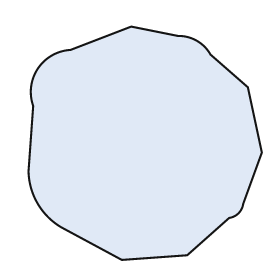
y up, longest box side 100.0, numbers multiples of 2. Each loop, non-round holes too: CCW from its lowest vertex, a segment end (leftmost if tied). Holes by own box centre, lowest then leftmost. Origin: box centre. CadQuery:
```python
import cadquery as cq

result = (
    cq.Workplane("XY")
    .moveTo(-10.0, -50.0)
    .lineTo(18.0, -48.0)
    .lineTo(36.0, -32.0)
    .threePointArc((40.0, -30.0), (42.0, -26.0))
    .lineTo(50.0, -4.0)
    .lineTo(44.0, 24.0)
    .lineTo(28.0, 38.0)
    .threePointArc((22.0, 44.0), (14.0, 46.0))
    .lineTo(-6.0, 50.0)
    .lineTo(-32.0, 40.0)
    .threePointArc((-46.0, 32.0), (-48.0, 16.0))
    .lineTo(-50.0, -12.0)
    .threePointArc((-46.0, -26.0), (-36.0, -36.0))
    .close()
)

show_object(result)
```